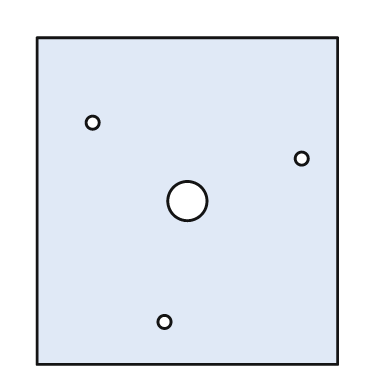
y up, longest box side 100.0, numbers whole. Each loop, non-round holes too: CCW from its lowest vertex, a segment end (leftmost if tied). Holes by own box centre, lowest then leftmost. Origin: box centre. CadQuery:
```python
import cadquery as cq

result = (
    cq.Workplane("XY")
    .moveTo(-46.0, -50.0)
    .lineTo(46.0, -50.0)
    .lineTo(46.0, 50.0)
    .lineTo(-46.0, 50.0)
    .close()
    .moveTo(-7.0, -37.0)
    .circle(2.0)
    .moveTo(0.0, 0.0)
    .circle(6.0)
    .moveTo(35.0, 13.0)
    .circle(2.0)
    .moveTo(-29.0, 24.0)
    .circle(2.0)
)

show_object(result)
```